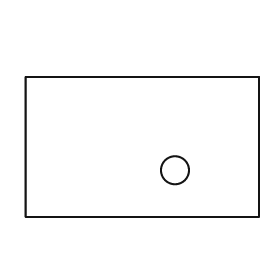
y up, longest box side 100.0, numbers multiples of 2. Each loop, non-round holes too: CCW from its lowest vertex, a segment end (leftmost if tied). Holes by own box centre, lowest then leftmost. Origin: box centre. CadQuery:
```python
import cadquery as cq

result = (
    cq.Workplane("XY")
    .moveTo(-50.0, -30.0)
    .lineTo(50.0, -30.0)
    .lineTo(50.0, 30.0)
    .lineTo(-50.0, 30.0)
    .close()
    .moveTo(14.0, -10.0)
    .circle(6.0)
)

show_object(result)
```